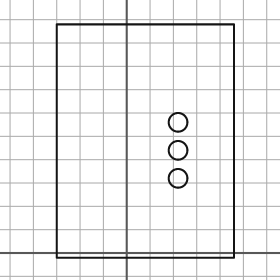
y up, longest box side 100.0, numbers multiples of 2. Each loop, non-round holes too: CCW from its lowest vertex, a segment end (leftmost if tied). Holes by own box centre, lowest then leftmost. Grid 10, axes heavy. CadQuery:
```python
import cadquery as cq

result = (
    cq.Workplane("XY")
    .moveTo(-30.0, -2.0)
    .lineTo(46.0, -2.0)
    .lineTo(46.0, 98.0)
    .lineTo(-30.0, 98.0)
    .close()
    .moveTo(22.0, 32.0)
    .circle(4.0)
    .moveTo(22.0, 44.0)
    .circle(4.0)
    .moveTo(22.0, 56.0)
    .circle(4.0)
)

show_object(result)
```